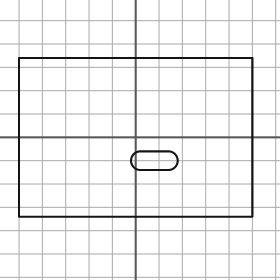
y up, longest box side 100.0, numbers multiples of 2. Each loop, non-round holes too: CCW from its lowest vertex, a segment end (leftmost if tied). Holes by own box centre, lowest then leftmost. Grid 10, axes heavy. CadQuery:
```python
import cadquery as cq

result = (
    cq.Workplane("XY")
    .moveTo(-50.0, -34.0)
    .lineTo(50.0, -34.0)
    .lineTo(50.0, 34.0)
    .lineTo(-50.0, 34.0)
    .close()
    .moveTo(2.0, -14.0)
    .lineTo(14.0, -14.0)
    .threePointArc((18.0, -10.0), (14.0, -6.0))
    .lineTo(2.0, -6.0)
    .threePointArc((-2.0, -10.0), (2.0, -14.0))
    .close()
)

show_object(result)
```